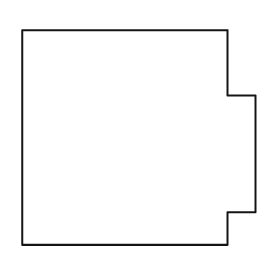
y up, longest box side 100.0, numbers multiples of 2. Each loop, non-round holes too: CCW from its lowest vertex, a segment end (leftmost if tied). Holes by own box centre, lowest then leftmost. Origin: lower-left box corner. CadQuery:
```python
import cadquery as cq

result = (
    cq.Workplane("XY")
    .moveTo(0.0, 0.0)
    .lineTo(88.0, 0.0)
    .lineTo(88.0, 14.0)
    .lineTo(100.0, 14.0)
    .lineTo(100.0, 64.0)
    .lineTo(88.0, 64.0)
    .lineTo(88.0, 92.0)
    .lineTo(0.0, 92.0)
    .close()
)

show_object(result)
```